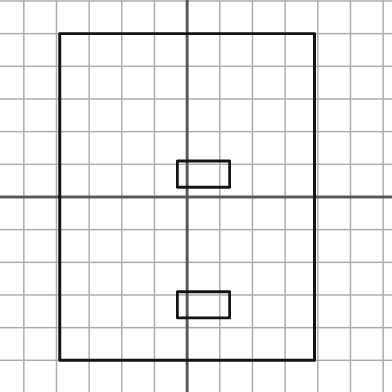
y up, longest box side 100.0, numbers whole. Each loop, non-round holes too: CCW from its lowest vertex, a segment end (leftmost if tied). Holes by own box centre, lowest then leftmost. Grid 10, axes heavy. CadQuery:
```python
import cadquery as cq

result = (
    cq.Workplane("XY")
    .moveTo(-39.0, -50.0)
    .lineTo(39.0, -50.0)
    .lineTo(39.0, 50.0)
    .lineTo(-39.0, 50.0)
    .close()
    .moveTo(-3.0, -37.0)
    .lineTo(13.0, -37.0)
    .lineTo(13.0, -29.0)
    .lineTo(-3.0, -29.0)
    .close()
    .moveTo(-3.0, 3.0)
    .lineTo(13.0, 3.0)
    .lineTo(13.0, 11.0)
    .lineTo(-3.0, 11.0)
    .close()
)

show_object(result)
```